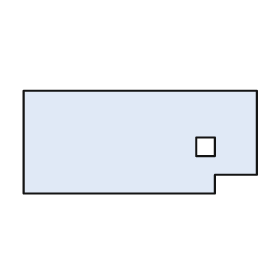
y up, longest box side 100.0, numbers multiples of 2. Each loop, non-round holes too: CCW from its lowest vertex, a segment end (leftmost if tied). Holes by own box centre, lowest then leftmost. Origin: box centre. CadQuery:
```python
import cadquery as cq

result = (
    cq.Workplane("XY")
    .moveTo(-50.0, -22.0)
    .lineTo(32.0, -22.0)
    .lineTo(32.0, -14.0)
    .lineTo(50.0, -14.0)
    .lineTo(50.0, 22.0)
    .lineTo(-50.0, 22.0)
    .close()
    .moveTo(24.0, -6.0)
    .lineTo(32.0, -6.0)
    .lineTo(32.0, 2.0)
    .lineTo(24.0, 2.0)
    .close()
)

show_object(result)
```